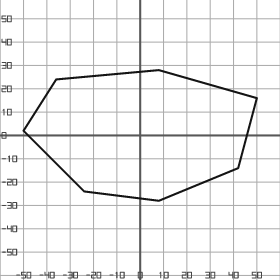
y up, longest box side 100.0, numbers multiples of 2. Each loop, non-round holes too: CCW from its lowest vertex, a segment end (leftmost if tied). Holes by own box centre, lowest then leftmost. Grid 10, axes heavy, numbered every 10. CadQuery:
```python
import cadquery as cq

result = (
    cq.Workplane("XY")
    .moveTo(8.0, -28.0)
    .lineTo(42.0, -14.0)
    .lineTo(50.0, 16.0)
    .lineTo(8.0, 28.0)
    .lineTo(-36.0, 24.0)
    .lineTo(-50.0, 2.0)
    .lineTo(-24.0, -24.0)
    .close()
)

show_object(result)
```